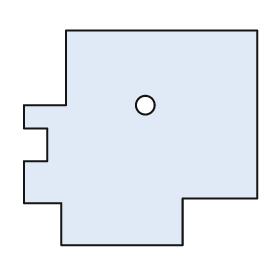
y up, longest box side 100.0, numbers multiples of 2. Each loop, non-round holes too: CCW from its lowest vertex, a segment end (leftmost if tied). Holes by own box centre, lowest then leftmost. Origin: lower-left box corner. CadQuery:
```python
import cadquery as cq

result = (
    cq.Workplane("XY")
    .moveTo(16.0, 0.0)
    .lineTo(68.0, 0.0)
    .lineTo(68.0, 20.0)
    .lineTo(100.0, 20.0)
    .lineTo(100.0, 92.0)
    .lineTo(18.0, 92.0)
    .lineTo(18.0, 60.0)
    .lineTo(0.0, 60.0)
    .lineTo(0.0, 50.0)
    .lineTo(10.0, 50.0)
    .lineTo(10.0, 36.0)
    .lineTo(0.0, 36.0)
    .lineTo(0.0, 18.0)
    .lineTo(16.0, 18.0)
    .close()
    .moveTo(52.0, 60.0)
    .circle(4.0)
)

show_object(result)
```